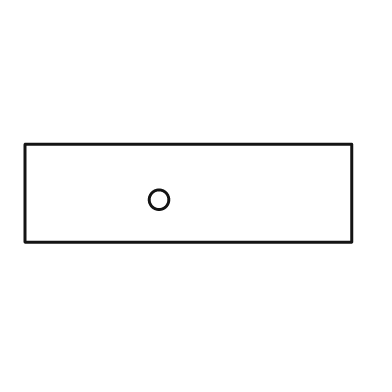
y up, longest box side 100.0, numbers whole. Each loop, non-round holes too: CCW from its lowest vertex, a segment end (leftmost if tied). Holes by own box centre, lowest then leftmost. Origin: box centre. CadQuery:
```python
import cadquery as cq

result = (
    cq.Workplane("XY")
    .moveTo(-50.0, -15.0)
    .lineTo(50.0, -15.0)
    .lineTo(50.0, 15.0)
    .lineTo(-50.0, 15.0)
    .close()
    .moveTo(-9.0, -2.0)
    .circle(3.0)
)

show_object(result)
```